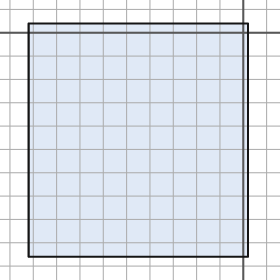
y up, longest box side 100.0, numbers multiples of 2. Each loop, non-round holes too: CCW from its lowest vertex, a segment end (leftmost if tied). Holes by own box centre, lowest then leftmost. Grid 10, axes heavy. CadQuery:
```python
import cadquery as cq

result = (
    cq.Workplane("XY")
    .moveTo(-92.0, -96.0)
    .lineTo(2.0, -96.0)
    .lineTo(2.0, 4.0)
    .lineTo(-92.0, 4.0)
    .close()
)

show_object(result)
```